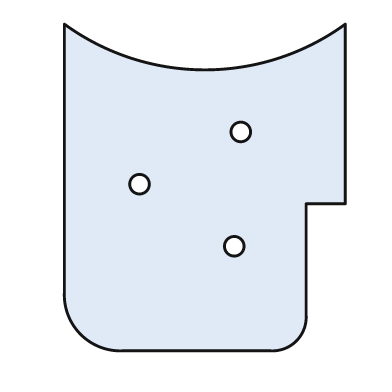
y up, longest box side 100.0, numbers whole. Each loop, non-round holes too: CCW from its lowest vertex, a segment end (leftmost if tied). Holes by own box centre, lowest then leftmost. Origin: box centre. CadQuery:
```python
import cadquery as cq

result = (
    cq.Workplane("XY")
    .moveTo(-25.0, -50.0)
    .lineTo(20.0, -50.0)
    .threePointArc((28.0, -47.0), (31.0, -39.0))
    .lineTo(31.0, -5.0)
    .lineTo(43.0, -5.0)
    .lineTo(43.0, 50.0)
    .threePointArc((0.0, 36.0), (-43.0, 50.0))
    .lineTo(-43.0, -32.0)
    .threePointArc((-38.0, -45.0), (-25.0, -50.0))
    .close()
    .moveTo(9.0, -18.0)
    .circle(3.0)
    .moveTo(-20.0, 1.0)
    .circle(3.0)
    .moveTo(11.0, 17.0)
    .circle(3.0)
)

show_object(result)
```